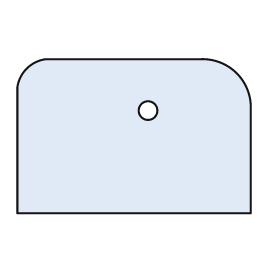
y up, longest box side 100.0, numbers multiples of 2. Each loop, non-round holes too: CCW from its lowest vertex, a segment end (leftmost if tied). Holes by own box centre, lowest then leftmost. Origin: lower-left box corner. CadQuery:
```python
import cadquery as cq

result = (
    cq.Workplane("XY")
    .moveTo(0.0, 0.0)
    .lineTo(100.0, 0.0)
    .lineTo(100.0, 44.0)
    .threePointArc((94.0, 60.0), (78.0, 66.0))
    .lineTo(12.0, 66.0)
    .threePointArc((4.0, 62.0), (0.0, 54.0))
    .close()
    .moveTo(56.0, 44.0)
    .circle(4.0)
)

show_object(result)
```